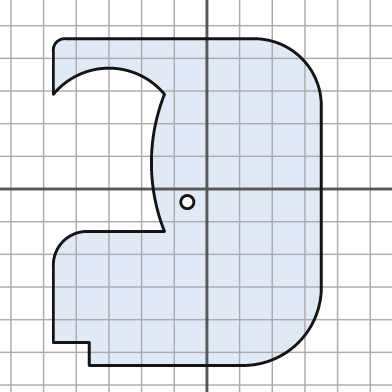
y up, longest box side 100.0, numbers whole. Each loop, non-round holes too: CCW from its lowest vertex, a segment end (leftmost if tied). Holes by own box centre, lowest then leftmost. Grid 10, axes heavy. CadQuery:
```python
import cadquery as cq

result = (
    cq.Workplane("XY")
    .moveTo(-36.0, -54.0)
    .lineTo(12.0, -54.0)
    .threePointArc((28.0, -47.0), (35.0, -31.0))
    .lineTo(35.0, 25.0)
    .threePointArc((29.0, 40.0), (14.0, 46.0))
    .lineTo(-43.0, 46.0)
    .threePointArc((-46.0, 45.0), (-47.0, 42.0))
    .lineTo(-47.0, 29.0)
    .threePointArc((-30.0, 37.0), (-13.0, 29.0))
    .threePointArc((-17.0, 8.0), (-13.0, -13.0))
    .lineTo(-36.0, -13.0)
    .threePointArc((-44.0, -16.0), (-47.0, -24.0))
    .lineTo(-47.0, -47.0)
    .lineTo(-36.0, -47.0)
    .close()
    .moveTo(-6.0, -4.0)
    .circle(2.0)
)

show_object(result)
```